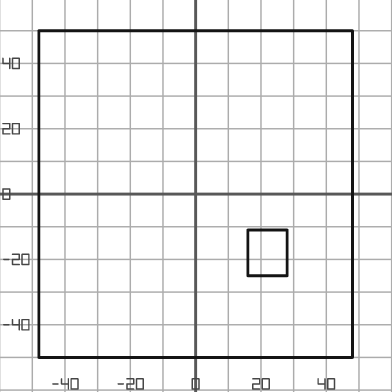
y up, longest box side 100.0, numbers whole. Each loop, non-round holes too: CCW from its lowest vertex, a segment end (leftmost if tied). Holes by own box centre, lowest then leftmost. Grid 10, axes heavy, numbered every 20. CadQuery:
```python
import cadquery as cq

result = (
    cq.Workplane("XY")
    .moveTo(-48.0, -50.0)
    .lineTo(48.0, -50.0)
    .lineTo(48.0, 50.0)
    .lineTo(-48.0, 50.0)
    .close()
    .moveTo(16.0, -25.0)
    .lineTo(28.0, -25.0)
    .lineTo(28.0, -11.0)
    .lineTo(16.0, -11.0)
    .close()
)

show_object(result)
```